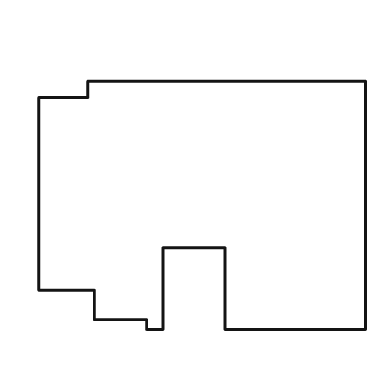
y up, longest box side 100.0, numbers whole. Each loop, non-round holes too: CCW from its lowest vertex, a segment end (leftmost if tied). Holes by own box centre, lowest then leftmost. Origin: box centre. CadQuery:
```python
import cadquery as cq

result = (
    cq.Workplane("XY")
    .moveTo(-17.0, -38.0)
    .lineTo(-12.0, -38.0)
    .lineTo(-12.0, -13.0)
    .lineTo(7.0, -13.0)
    .lineTo(7.0, -38.0)
    .lineTo(50.0, -38.0)
    .lineTo(50.0, 38.0)
    .lineTo(-35.0, 38.0)
    .lineTo(-35.0, 33.0)
    .lineTo(-50.0, 33.0)
    .lineTo(-50.0, -26.0)
    .lineTo(-33.0, -26.0)
    .lineTo(-33.0, -35.0)
    .lineTo(-17.0, -35.0)
    .close()
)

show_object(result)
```